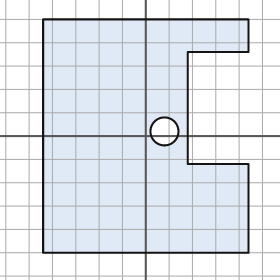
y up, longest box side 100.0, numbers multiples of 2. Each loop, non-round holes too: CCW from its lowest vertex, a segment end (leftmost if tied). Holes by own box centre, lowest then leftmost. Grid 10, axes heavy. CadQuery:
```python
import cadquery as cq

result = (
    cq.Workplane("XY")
    .moveTo(-44.0, -50.0)
    .lineTo(44.0, -50.0)
    .lineTo(44.0, -12.0)
    .lineTo(18.0, -12.0)
    .lineTo(18.0, 36.0)
    .lineTo(44.0, 36.0)
    .lineTo(44.0, 50.0)
    .lineTo(-44.0, 50.0)
    .close()
    .moveTo(8.0, 2.0)
    .circle(6.0)
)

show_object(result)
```